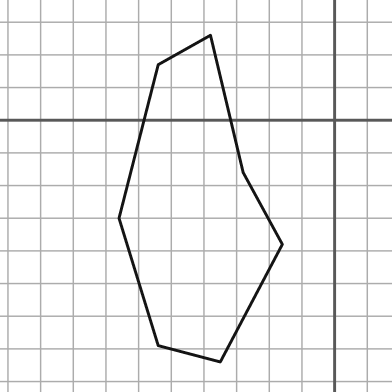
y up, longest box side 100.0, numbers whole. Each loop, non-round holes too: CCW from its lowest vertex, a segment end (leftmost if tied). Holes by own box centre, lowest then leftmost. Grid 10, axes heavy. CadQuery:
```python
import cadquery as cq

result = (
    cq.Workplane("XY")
    .moveTo(-35.0, -74.0)
    .lineTo(-16.0, -38.0)
    .lineTo(-28.0, -16.0)
    .lineTo(-38.0, 26.0)
    .lineTo(-54.0, 17.0)
    .lineTo(-66.0, -30.0)
    .lineTo(-54.0, -69.0)
    .close()
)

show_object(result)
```